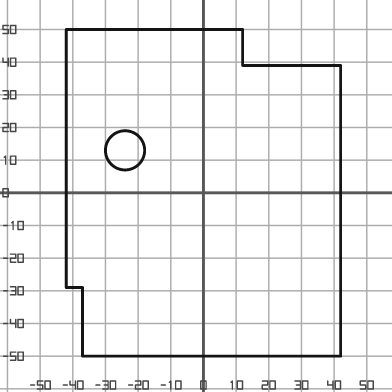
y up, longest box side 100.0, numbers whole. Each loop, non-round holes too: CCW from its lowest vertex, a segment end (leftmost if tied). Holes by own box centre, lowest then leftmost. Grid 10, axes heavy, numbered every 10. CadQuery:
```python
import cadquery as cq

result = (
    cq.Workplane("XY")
    .moveTo(-37.0, -50.0)
    .lineTo(42.0, -50.0)
    .lineTo(42.0, 39.0)
    .lineTo(12.0, 39.0)
    .lineTo(12.0, 50.0)
    .lineTo(-42.0, 50.0)
    .lineTo(-42.0, -29.0)
    .lineTo(-37.0, -29.0)
    .close()
    .moveTo(-24.0, 13.0)
    .circle(6.0)
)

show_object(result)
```